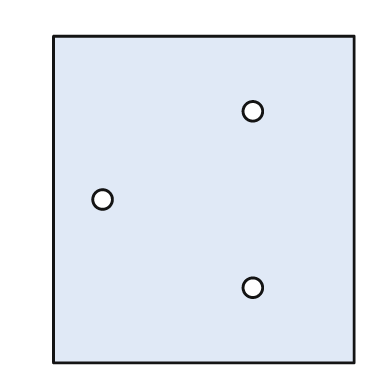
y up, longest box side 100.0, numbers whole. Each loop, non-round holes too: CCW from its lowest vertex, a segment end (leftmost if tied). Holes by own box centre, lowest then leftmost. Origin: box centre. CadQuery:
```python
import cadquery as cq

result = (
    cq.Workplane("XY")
    .moveTo(-46.0, -50.0)
    .lineTo(46.0, -50.0)
    .lineTo(46.0, 50.0)
    .lineTo(-46.0, 50.0)
    .close()
    .moveTo(15.0, -27.0)
    .circle(3.0)
    .moveTo(-31.0, 0.0)
    .circle(3.0)
    .moveTo(15.0, 27.0)
    .circle(3.0)
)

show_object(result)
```